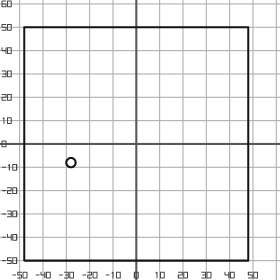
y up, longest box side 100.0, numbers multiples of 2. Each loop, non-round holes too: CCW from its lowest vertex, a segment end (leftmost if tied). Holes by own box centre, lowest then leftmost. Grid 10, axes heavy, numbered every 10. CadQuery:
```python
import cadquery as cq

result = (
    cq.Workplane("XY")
    .moveTo(-48.0, -50.0)
    .lineTo(48.0, -50.0)
    .lineTo(48.0, 50.0)
    .lineTo(-48.0, 50.0)
    .close()
    .moveTo(-28.0, -8.0)
    .circle(2.0)
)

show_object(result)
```